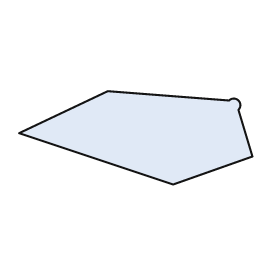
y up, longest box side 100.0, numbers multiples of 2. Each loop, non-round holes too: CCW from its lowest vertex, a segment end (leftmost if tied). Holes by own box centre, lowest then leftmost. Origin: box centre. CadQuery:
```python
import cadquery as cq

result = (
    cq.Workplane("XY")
    .moveTo(16.0, -20.0)
    .lineTo(50.0, -8.0)
    .lineTo(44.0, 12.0)
    .threePointArc((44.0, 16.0), (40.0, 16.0))
    .lineTo(-12.0, 20.0)
    .lineTo(-50.0, 2.0)
    .close()
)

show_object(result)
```